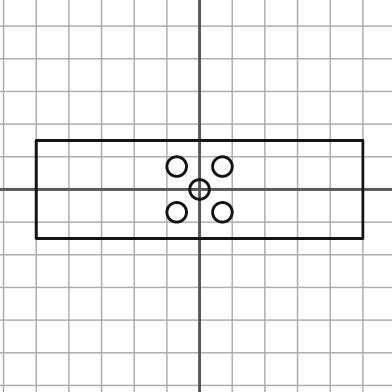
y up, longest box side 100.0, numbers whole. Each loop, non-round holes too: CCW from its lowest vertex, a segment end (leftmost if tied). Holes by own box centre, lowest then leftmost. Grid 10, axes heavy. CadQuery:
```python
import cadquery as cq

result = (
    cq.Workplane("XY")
    .moveTo(-50.0, -15.0)
    .lineTo(50.0, -15.0)
    .lineTo(50.0, 15.0)
    .lineTo(-50.0, 15.0)
    .close()
    .moveTo(-7.0, -7.0)
    .circle(3.0)
    .moveTo(7.0, -7.0)
    .circle(3.0)
    .moveTo(0.0, 0.0)
    .circle(3.0)
    .moveTo(-7.0, 7.0)
    .circle(3.0)
    .moveTo(7.0, 7.0)
    .circle(3.0)
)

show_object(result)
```